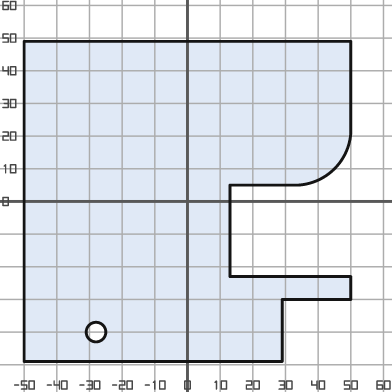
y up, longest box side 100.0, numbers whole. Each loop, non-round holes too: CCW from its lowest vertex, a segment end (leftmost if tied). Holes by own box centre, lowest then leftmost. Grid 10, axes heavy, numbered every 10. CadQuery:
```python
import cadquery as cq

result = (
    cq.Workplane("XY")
    .moveTo(-50.0, -49.0)
    .lineTo(29.0, -49.0)
    .lineTo(29.0, -30.0)
    .lineTo(50.0, -30.0)
    .lineTo(50.0, -23.0)
    .lineTo(13.0, -23.0)
    .lineTo(13.0, 5.0)
    .lineTo(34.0, 5.0)
    .threePointArc((45.0, 10.0), (50.0, 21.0))
    .lineTo(50.0, 49.0)
    .lineTo(-50.0, 49.0)
    .close()
    .moveTo(-28.0, -40.0)
    .circle(3.0)
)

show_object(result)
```